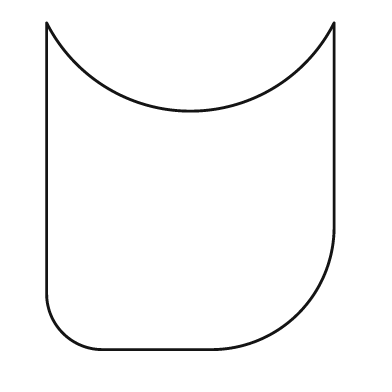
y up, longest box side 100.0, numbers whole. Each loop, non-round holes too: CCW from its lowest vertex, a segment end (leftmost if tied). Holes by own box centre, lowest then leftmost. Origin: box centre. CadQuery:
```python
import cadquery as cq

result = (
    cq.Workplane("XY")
    .moveTo(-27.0, -50.0)
    .lineTo(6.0, -50.0)
    .threePointArc((33.0, -39.0), (44.0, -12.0))
    .lineTo(44.0, 50.0)
    .threePointArc((0.0, 23.0), (-44.0, 50.0))
    .lineTo(-44.0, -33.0)
    .threePointArc((-39.0, -45.0), (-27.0, -50.0))
    .close()
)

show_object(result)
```